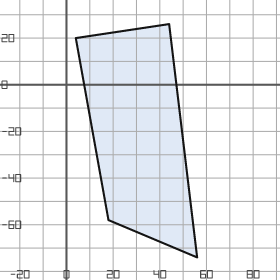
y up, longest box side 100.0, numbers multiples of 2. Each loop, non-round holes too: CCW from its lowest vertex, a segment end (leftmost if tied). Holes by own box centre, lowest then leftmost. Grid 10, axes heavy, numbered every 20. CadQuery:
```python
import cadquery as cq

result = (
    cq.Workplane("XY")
    .moveTo(56.0, -74.0)
    .lineTo(44.0, 26.0)
    .lineTo(4.0, 20.0)
    .lineTo(18.0, -58.0)
    .close()
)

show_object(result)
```